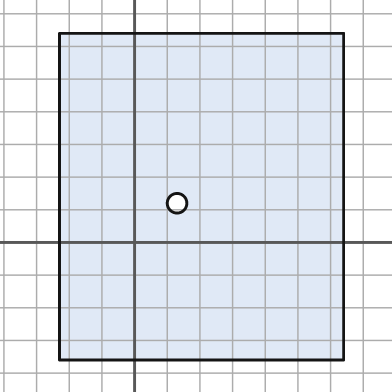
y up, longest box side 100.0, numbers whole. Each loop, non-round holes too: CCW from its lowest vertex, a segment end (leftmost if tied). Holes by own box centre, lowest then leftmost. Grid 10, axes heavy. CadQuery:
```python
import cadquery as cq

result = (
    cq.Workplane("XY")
    .moveTo(-23.0, -36.0)
    .lineTo(64.0, -36.0)
    .lineTo(64.0, 64.0)
    .lineTo(-23.0, 64.0)
    .close()
    .moveTo(13.0, 12.0)
    .circle(3.0)
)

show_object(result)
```